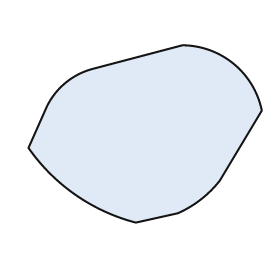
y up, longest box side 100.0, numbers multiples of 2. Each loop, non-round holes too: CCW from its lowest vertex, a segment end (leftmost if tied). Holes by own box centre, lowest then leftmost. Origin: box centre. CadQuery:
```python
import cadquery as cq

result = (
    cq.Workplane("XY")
    .moveTo(-4.0, -38.0)
    .lineTo(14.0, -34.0)
    .threePointArc((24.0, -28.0), (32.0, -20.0))
    .lineTo(50.0, 10.0)
    .threePointArc((38.0, 30.0), (16.0, 38.0))
    .lineTo(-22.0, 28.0)
    .threePointArc((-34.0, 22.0), (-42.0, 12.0))
    .lineTo(-50.0, -6.0)
    .threePointArc((-30.0, -26.0), (-4.0, -38.0))
    .close()
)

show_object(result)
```